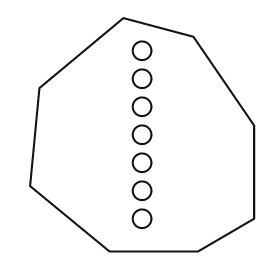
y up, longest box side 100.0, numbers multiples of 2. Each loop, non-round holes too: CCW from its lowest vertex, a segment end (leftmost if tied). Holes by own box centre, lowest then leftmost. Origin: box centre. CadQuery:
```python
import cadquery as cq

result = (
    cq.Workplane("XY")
    .moveTo(-14.0, -50.0)
    .lineTo(24.0, -50.0)
    .lineTo(48.0, -36.0)
    .lineTo(48.0, 4.0)
    .lineTo(22.0, 42.0)
    .lineTo(-8.0, 50.0)
    .lineTo(-44.0, 20.0)
    .lineTo(-48.0, -22.0)
    .close()
    .moveTo(0.0, -36.0)
    .circle(4.0)
    .moveTo(0.0, -24.0)
    .circle(4.0)
    .moveTo(0.0, -12.0)
    .circle(4.0)
    .moveTo(0.0, 0.0)
    .circle(4.0)
    .moveTo(0.0, 12.0)
    .circle(4.0)
    .moveTo(0.0, 24.0)
    .circle(4.0)
    .moveTo(0.0, 36.0)
    .circle(4.0)
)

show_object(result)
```